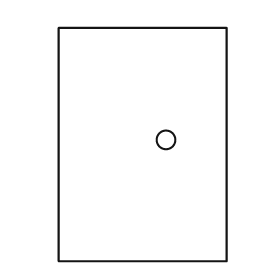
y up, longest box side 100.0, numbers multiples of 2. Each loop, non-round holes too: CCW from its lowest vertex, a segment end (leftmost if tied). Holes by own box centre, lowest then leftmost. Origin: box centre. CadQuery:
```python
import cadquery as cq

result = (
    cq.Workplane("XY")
    .moveTo(-36.0, -50.0)
    .lineTo(36.0, -50.0)
    .lineTo(36.0, 50.0)
    .lineTo(-36.0, 50.0)
    .close()
    .moveTo(10.0, 2.0)
    .circle(4.0)
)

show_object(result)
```